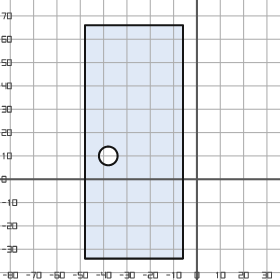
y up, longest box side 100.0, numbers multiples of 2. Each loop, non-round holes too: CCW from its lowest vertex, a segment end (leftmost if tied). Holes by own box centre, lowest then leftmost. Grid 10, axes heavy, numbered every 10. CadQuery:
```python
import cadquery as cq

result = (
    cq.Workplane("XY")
    .moveTo(-48.0, -34.0)
    .lineTo(-6.0, -34.0)
    .lineTo(-6.0, 66.0)
    .lineTo(-48.0, 66.0)
    .close()
    .moveTo(-38.0, 10.0)
    .circle(4.0)
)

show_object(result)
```